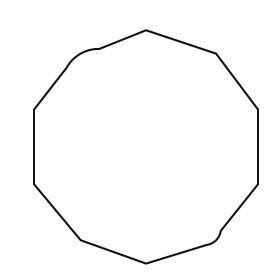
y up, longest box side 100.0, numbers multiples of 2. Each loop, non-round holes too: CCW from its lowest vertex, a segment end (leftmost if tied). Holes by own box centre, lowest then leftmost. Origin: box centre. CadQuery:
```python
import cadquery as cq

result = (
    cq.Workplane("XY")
    .moveTo(0.0, -50.0)
    .lineTo(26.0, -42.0)
    .threePointArc((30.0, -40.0), (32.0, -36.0))
    .lineTo(48.0, -16.0)
    .lineTo(48.0, 16.0)
    .lineTo(30.0, 40.0)
    .lineTo(0.0, 50.0)
    .lineTo(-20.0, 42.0)
    .threePointArc((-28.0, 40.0), (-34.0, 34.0))
    .lineTo(-48.0, 16.0)
    .lineTo(-48.0, -16.0)
    .lineTo(-28.0, -40.0)
    .close()
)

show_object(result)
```